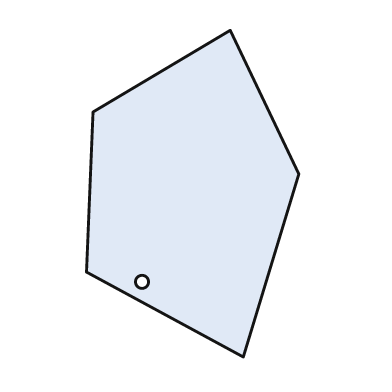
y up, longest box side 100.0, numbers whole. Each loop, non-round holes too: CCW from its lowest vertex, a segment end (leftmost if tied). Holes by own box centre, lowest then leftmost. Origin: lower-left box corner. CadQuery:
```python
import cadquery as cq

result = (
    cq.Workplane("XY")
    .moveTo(48.0, 0.0)
    .lineTo(65.0, 56.0)
    .lineTo(44.0, 100.0)
    .lineTo(2.0, 75.0)
    .lineTo(0.0, 26.0)
    .close()
    .moveTo(17.0, 23.0)
    .circle(2.0)
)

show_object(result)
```